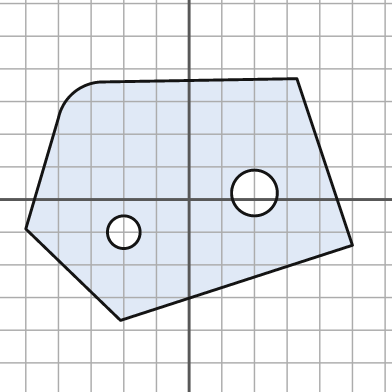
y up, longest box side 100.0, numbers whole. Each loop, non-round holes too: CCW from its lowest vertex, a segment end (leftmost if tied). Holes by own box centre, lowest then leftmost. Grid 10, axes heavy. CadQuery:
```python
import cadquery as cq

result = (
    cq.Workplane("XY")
    .moveTo(-21.0, -37.0)
    .lineTo(50.0, -14.0)
    .lineTo(33.0, 37.0)
    .lineTo(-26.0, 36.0)
    .threePointArc((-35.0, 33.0), (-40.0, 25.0))
    .lineTo(-50.0, -9.0)
    .close()
    .moveTo(-20.0, -10.0)
    .circle(5.0)
    .moveTo(20.0, 2.0)
    .circle(7.0)
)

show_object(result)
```